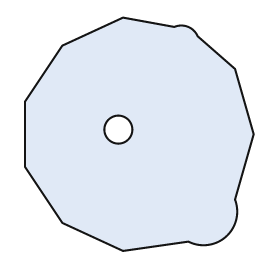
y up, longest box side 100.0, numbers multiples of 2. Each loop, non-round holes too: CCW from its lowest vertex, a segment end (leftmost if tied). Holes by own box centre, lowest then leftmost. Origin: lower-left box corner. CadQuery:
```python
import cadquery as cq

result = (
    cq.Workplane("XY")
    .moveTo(42.0, 0.0)
    .lineTo(70.0, 4.0)
    .threePointArc((86.0, 6.0), (90.0, 22.0))
    .lineTo(98.0, 50.0)
    .lineTo(90.0, 78.0)
    .lineTo(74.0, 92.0)
    .threePointArc((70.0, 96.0), (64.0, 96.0))
    .lineTo(42.0, 100.0)
    .lineTo(16.0, 88.0)
    .lineTo(0.0, 64.0)
    .lineTo(0.0, 36.0)
    .lineTo(16.0, 12.0)
    .close()
    .moveTo(40.0, 52.0)
    .circle(6.0)
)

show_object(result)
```